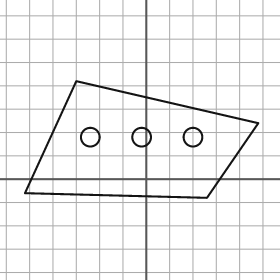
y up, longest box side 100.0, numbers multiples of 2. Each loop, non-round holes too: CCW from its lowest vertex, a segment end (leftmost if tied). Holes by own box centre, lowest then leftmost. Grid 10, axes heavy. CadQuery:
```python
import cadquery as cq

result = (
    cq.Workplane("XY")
    .moveTo(26.0, -8.0)
    .lineTo(48.0, 24.0)
    .lineTo(-30.0, 42.0)
    .lineTo(-52.0, -6.0)
    .close()
    .moveTo(-24.0, 18.0)
    .circle(4.0)
    .moveTo(-2.0, 18.0)
    .circle(4.0)
    .moveTo(20.0, 18.0)
    .circle(4.0)
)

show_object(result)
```